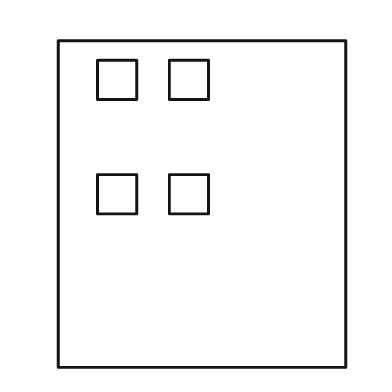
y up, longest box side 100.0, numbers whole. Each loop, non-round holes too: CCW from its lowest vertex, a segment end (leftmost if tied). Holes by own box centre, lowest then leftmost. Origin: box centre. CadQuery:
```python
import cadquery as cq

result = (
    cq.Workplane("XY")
    .moveTo(-44.0, -50.0)
    .lineTo(44.0, -50.0)
    .lineTo(44.0, 50.0)
    .lineTo(-44.0, 50.0)
    .close()
    .moveTo(-32.0, -3.0)
    .lineTo(-20.0, -3.0)
    .lineTo(-20.0, 9.0)
    .lineTo(-32.0, 9.0)
    .close()
    .moveTo(-10.0, -3.0)
    .lineTo(2.0, -3.0)
    .lineTo(2.0, 9.0)
    .lineTo(-10.0, 9.0)
    .close()
    .moveTo(-32.0, 32.0)
    .lineTo(-20.0, 32.0)
    .lineTo(-20.0, 44.0)
    .lineTo(-32.0, 44.0)
    .close()
    .moveTo(-10.0, 32.0)
    .lineTo(2.0, 32.0)
    .lineTo(2.0, 44.0)
    .lineTo(-10.0, 44.0)
    .close()
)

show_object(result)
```